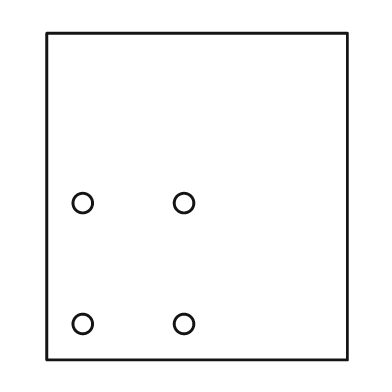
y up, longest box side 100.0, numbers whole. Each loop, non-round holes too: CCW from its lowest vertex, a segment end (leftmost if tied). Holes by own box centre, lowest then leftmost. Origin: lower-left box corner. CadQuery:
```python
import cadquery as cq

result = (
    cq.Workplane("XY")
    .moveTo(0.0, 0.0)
    .lineTo(92.0, 0.0)
    .lineTo(92.0, 100.0)
    .lineTo(0.0, 100.0)
    .close()
    .moveTo(11.0, 11.0)
    .circle(3.0)
    .moveTo(42.0, 11.0)
    .circle(3.0)
    .moveTo(11.0, 48.0)
    .circle(3.0)
    .moveTo(42.0, 48.0)
    .circle(3.0)
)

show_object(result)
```